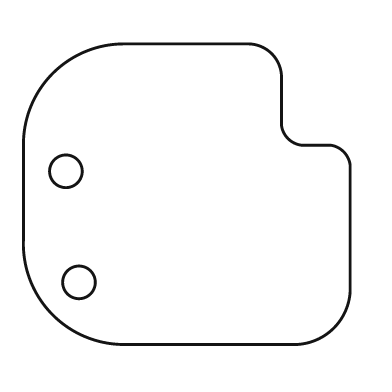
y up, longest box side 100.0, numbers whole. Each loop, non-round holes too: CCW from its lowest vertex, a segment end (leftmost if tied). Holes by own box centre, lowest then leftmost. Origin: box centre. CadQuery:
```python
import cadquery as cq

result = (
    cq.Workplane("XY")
    .moveTo(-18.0, -46.0)
    .lineTo(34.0, -46.0)
    .threePointArc((45.0, -41.0), (50.0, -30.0))
    .lineTo(50.0, 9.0)
    .threePointArc((48.0, 13.0), (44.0, 15.0))
    .lineTo(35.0, 15.0)
    .threePointArc((31.0, 17.0), (29.0, 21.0))
    .lineTo(29.0, 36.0)
    .threePointArc((26.0, 43.0), (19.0, 46.0))
    .lineTo(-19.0, 46.0)
    .threePointArc((-41.0, 37.0), (-50.0, 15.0))
    .lineTo(-50.0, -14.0)
    .threePointArc((-41.0, -37.0), (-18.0, -46.0))
    .close()
    .moveTo(-33.0, -27.0)
    .circle(5.0)
    .moveTo(-37.0, 7.0)
    .circle(5.0)
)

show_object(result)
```